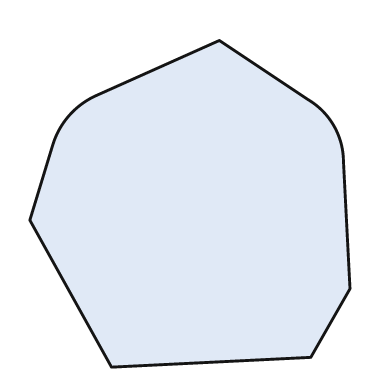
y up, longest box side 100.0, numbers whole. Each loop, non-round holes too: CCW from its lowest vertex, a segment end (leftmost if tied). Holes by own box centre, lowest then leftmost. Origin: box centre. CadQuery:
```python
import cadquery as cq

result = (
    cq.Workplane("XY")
    .moveTo(-24.0, -50.0)
    .lineTo(37.0, -47.0)
    .lineTo(49.0, -26.0)
    .lineTo(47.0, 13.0)
    .threePointArc((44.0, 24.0), (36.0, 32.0))
    .lineTo(9.0, 50.0)
    .lineTo(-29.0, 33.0)
    .threePointArc((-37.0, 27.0), (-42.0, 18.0))
    .lineTo(-49.0, -5.0)
    .close()
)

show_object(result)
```